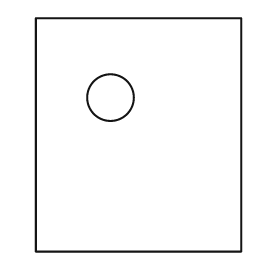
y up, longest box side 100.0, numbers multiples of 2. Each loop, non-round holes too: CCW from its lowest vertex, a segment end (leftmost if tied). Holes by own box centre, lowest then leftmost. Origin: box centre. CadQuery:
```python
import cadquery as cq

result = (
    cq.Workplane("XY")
    .moveTo(-44.0, -50.0)
    .lineTo(44.0, -50.0)
    .lineTo(44.0, 50.0)
    .lineTo(-44.0, 50.0)
    .close()
    .moveTo(-12.0, 16.0)
    .circle(10.0)
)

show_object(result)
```